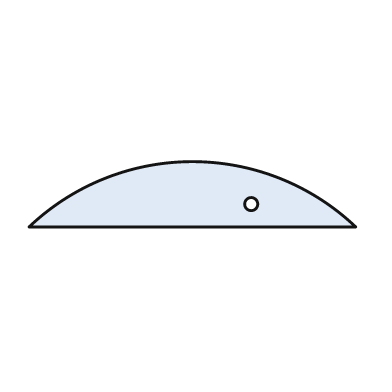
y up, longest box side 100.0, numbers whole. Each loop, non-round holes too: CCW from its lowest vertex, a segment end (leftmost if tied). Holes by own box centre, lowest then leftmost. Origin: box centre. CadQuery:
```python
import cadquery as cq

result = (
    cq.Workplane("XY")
    .moveTo(-50.0, -10.0)
    .lineTo(50.0, -10.0)
    .threePointArc((0.0, 10.0), (-50.0, -10.0))
    .close()
    .moveTo(18.0, -3.0)
    .circle(2.0)
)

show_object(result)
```